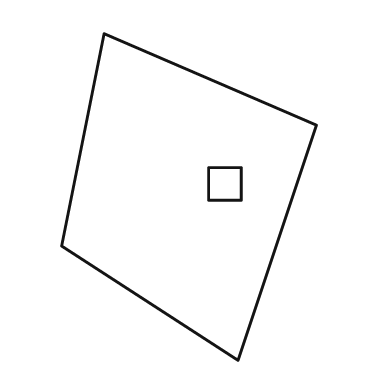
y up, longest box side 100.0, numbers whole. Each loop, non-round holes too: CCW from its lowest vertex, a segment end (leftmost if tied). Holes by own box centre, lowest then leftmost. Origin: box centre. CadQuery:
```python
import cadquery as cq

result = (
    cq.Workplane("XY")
    .moveTo(15.0, -50.0)
    .lineTo(39.0, 22.0)
    .lineTo(-26.0, 50.0)
    .lineTo(-39.0, -15.0)
    .close()
    .moveTo(6.0, -1.0)
    .lineTo(16.0, -1.0)
    .lineTo(16.0, 9.0)
    .lineTo(6.0, 9.0)
    .close()
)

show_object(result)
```